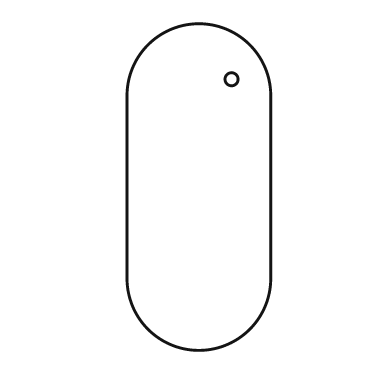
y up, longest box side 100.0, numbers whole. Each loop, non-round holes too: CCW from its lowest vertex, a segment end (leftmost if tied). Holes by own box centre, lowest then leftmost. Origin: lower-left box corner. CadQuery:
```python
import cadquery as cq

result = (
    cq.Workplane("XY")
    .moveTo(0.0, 22.0)
    .threePointArc((22.0, 0.0), (44.0, 22.0))
    .lineTo(44.0, 78.0)
    .threePointArc((22.0, 100.0), (0.0, 78.0))
    .close()
    .moveTo(32.0, 83.0)
    .circle(2.0)
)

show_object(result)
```